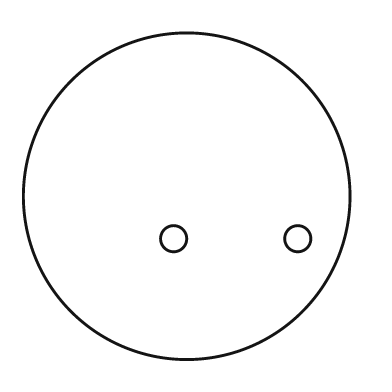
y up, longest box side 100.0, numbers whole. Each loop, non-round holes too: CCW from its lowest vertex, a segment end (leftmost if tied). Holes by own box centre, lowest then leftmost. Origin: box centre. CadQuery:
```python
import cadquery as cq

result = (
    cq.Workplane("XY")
    .moveTo(0.0, 0.0)
    .circle(50.0)
    .moveTo(-4.0, -13.0)
    .circle(4.0)
    .moveTo(34.0, -13.0)
    .circle(4.0)
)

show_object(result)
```